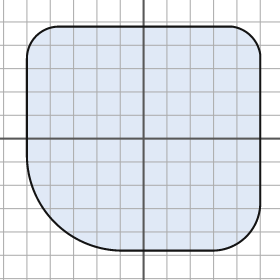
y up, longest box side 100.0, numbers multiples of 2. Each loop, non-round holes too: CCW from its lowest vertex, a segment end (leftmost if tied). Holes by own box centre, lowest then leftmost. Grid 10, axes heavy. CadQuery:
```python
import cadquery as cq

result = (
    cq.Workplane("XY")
    .moveTo(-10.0, -48.0)
    .lineTo(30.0, -48.0)
    .threePointArc((44.0, -42.0), (50.0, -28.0))
    .lineTo(50.0, 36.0)
    .threePointArc((46.0, 44.0), (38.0, 48.0))
    .lineTo(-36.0, 48.0)
    .threePointArc((-46.0, 44.0), (-50.0, 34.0))
    .lineTo(-50.0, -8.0)
    .threePointArc((-38.0, -36.0), (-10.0, -48.0))
    .close()
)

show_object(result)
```